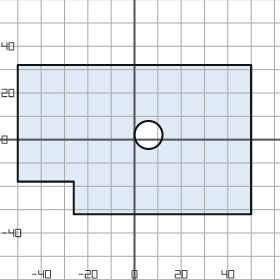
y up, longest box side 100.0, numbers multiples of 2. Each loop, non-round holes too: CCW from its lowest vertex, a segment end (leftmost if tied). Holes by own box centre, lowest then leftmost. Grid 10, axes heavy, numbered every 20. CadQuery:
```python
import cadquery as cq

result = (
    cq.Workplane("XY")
    .moveTo(-26.0, -32.0)
    .lineTo(50.0, -32.0)
    .lineTo(50.0, 32.0)
    .lineTo(-50.0, 32.0)
    .lineTo(-50.0, -18.0)
    .lineTo(-26.0, -18.0)
    .close()
    .moveTo(6.0, 2.0)
    .circle(6.0)
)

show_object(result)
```